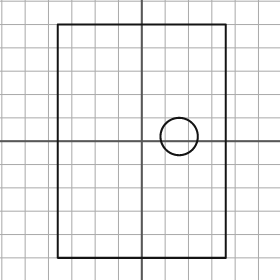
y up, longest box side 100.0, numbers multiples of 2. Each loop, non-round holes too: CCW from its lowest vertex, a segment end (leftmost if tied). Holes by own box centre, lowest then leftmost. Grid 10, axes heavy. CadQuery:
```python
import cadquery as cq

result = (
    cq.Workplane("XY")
    .moveTo(-36.0, -50.0)
    .lineTo(36.0, -50.0)
    .lineTo(36.0, 50.0)
    .lineTo(-36.0, 50.0)
    .close()
    .moveTo(16.0, 2.0)
    .circle(8.0)
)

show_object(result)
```